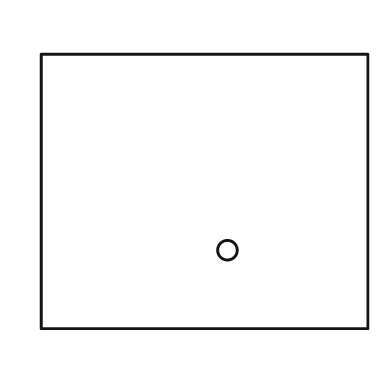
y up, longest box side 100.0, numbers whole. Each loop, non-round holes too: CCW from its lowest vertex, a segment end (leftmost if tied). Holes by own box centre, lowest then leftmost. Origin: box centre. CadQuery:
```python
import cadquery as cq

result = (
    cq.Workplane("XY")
    .moveTo(-50.0, -42.0)
    .lineTo(50.0, -42.0)
    .lineTo(50.0, 42.0)
    .lineTo(-50.0, 42.0)
    .close()
    .moveTo(7.0, -18.0)
    .circle(3.0)
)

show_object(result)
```